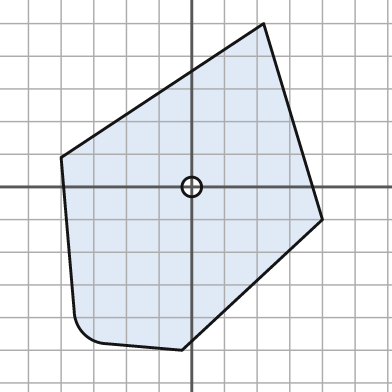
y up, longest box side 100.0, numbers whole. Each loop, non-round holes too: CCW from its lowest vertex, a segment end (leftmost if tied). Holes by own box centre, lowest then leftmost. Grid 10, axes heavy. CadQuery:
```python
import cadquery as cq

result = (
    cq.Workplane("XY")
    .moveTo(-3.0, -50.0)
    .lineTo(40.0, -10.0)
    .lineTo(22.0, 50.0)
    .lineTo(-40.0, 9.0)
    .lineTo(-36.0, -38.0)
    .threePointArc((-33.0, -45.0), (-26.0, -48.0))
    .close()
    .moveTo(0.0, 0.0)
    .circle(3.0)
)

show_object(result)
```